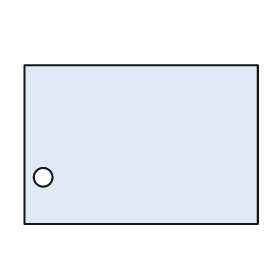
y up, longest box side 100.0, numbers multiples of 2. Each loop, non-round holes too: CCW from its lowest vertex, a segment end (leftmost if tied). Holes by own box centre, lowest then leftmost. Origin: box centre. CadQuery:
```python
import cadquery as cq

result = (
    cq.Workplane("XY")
    .moveTo(-50.0, -34.0)
    .lineTo(50.0, -34.0)
    .lineTo(50.0, 34.0)
    .lineTo(-50.0, 34.0)
    .close()
    .moveTo(-42.0, -14.0)
    .circle(4.0)
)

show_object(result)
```